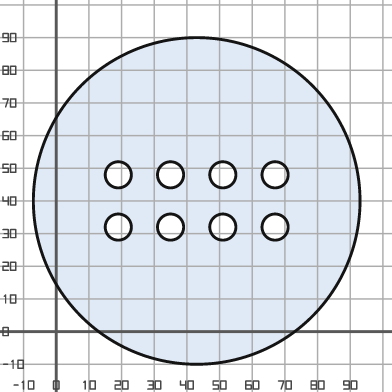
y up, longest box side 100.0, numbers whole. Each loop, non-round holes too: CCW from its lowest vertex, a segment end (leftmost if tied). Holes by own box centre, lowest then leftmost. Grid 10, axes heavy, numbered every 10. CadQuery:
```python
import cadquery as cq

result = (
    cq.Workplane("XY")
    .moveTo(43.0, 40.0)
    .circle(50.0)
    .moveTo(19.0, 32.0)
    .circle(4.0)
    .moveTo(35.0, 32.0)
    .circle(4.0)
    .moveTo(51.0, 32.0)
    .circle(4.0)
    .moveTo(67.0, 32.0)
    .circle(4.0)
    .moveTo(19.0, 48.0)
    .circle(4.0)
    .moveTo(35.0, 48.0)
    .circle(4.0)
    .moveTo(51.0, 48.0)
    .circle(4.0)
    .moveTo(67.0, 48.0)
    .circle(4.0)
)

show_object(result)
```